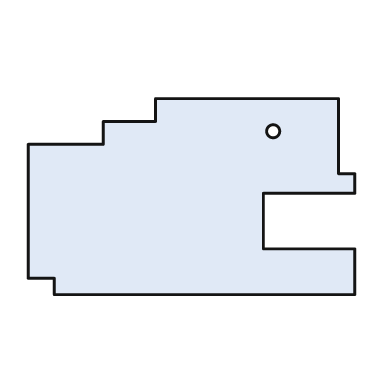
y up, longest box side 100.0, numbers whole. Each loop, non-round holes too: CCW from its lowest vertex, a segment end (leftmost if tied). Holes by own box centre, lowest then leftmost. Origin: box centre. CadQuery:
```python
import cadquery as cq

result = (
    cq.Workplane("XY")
    .moveTo(-42.0, -30.0)
    .lineTo(50.0, -30.0)
    .lineTo(50.0, -16.0)
    .lineTo(22.0, -16.0)
    .lineTo(22.0, 1.0)
    .lineTo(50.0, 1.0)
    .lineTo(50.0, 7.0)
    .lineTo(45.0, 7.0)
    .lineTo(45.0, 30.0)
    .lineTo(-11.0, 30.0)
    .lineTo(-11.0, 23.0)
    .lineTo(-27.0, 23.0)
    .lineTo(-27.0, 16.0)
    .lineTo(-50.0, 16.0)
    .lineTo(-50.0, -25.0)
    .lineTo(-42.0, -25.0)
    .close()
    .moveTo(25.0, 20.0)
    .circle(2.0)
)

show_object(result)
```